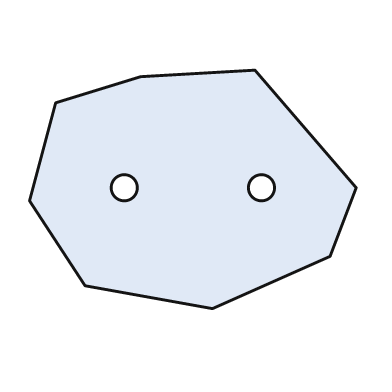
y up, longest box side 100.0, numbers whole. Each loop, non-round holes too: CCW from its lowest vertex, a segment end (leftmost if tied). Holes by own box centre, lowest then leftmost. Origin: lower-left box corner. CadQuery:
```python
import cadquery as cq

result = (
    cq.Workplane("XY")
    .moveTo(56.0, 0.0)
    .lineTo(92.0, 16.0)
    .lineTo(100.0, 37.0)
    .lineTo(69.0, 73.0)
    .lineTo(34.0, 71.0)
    .lineTo(8.0, 63.0)
    .lineTo(0.0, 33.0)
    .lineTo(17.0, 7.0)
    .close()
    .moveTo(29.0, 37.0)
    .circle(4.0)
    .moveTo(71.0, 37.0)
    .circle(4.0)
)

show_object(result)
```